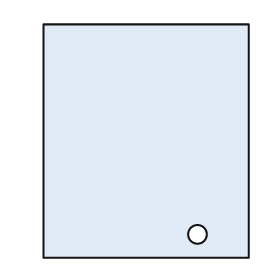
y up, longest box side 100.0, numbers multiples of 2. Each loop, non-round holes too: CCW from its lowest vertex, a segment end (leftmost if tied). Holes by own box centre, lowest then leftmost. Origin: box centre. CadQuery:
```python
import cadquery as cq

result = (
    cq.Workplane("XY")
    .moveTo(-44.0, -50.0)
    .lineTo(44.0, -50.0)
    .lineTo(44.0, 50.0)
    .lineTo(-44.0, 50.0)
    .close()
    .moveTo(22.0, -40.0)
    .circle(4.0)
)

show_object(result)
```